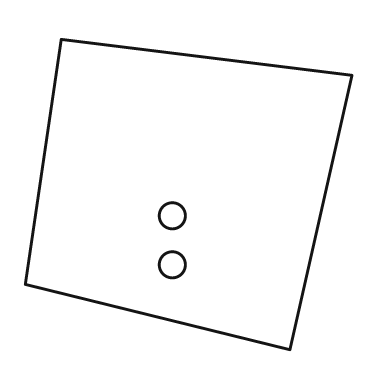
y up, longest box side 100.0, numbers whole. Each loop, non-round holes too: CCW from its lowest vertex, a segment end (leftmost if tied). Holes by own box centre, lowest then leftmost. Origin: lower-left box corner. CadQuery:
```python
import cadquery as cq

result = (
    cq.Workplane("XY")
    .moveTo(81.0, 0.0)
    .lineTo(100.0, 84.0)
    .lineTo(11.0, 95.0)
    .lineTo(0.0, 20.0)
    .close()
    .moveTo(45.0, 26.0)
    .circle(4.0)
    .moveTo(45.0, 41.0)
    .circle(4.0)
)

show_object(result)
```